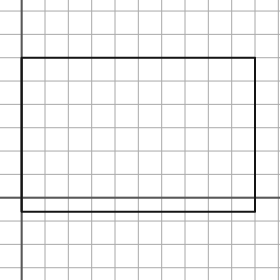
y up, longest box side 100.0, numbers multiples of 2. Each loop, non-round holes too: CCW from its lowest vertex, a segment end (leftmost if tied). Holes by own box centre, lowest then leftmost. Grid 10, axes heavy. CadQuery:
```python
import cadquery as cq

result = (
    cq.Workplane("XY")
    .moveTo(0.0, -6.0)
    .lineTo(100.0, -6.0)
    .lineTo(100.0, 60.0)
    .lineTo(0.0, 60.0)
    .close()
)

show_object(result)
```